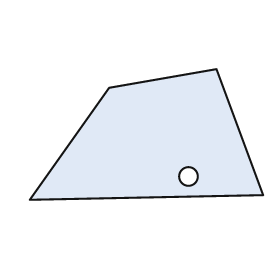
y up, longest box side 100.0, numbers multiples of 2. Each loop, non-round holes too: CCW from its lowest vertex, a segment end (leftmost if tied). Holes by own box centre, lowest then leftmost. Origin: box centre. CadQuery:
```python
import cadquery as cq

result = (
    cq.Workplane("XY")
    .moveTo(-50.0, -28.0)
    .lineTo(50.0, -26.0)
    .lineTo(30.0, 28.0)
    .lineTo(-16.0, 20.0)
    .close()
    .moveTo(18.0, -18.0)
    .circle(4.0)
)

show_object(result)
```